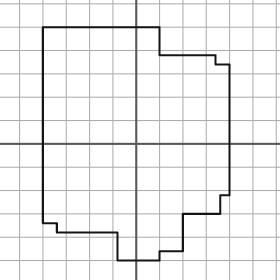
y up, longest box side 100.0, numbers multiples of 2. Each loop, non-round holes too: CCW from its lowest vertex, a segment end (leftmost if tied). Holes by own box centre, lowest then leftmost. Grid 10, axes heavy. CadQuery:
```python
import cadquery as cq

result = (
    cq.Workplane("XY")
    .moveTo(-8.0, -50.0)
    .lineTo(10.0, -50.0)
    .lineTo(10.0, -46.0)
    .lineTo(20.0, -46.0)
    .lineTo(20.0, -30.0)
    .lineTo(36.0, -30.0)
    .lineTo(36.0, -22.0)
    .lineTo(40.0, -22.0)
    .lineTo(40.0, 34.0)
    .lineTo(34.0, 34.0)
    .lineTo(34.0, 38.0)
    .lineTo(10.0, 38.0)
    .lineTo(10.0, 50.0)
    .lineTo(-40.0, 50.0)
    .lineTo(-40.0, -34.0)
    .lineTo(-34.0, -34.0)
    .lineTo(-34.0, -38.0)
    .lineTo(-8.0, -38.0)
    .close()
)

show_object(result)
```